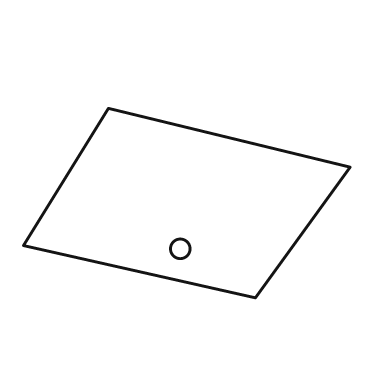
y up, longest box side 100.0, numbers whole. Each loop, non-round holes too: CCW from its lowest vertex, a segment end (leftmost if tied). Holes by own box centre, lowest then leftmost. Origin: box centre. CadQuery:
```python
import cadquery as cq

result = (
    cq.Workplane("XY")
    .moveTo(21.0, -29.0)
    .lineTo(50.0, 11.0)
    .lineTo(-24.0, 29.0)
    .lineTo(-50.0, -13.0)
    .close()
    .moveTo(-2.0, -14.0)
    .circle(3.0)
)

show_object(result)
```